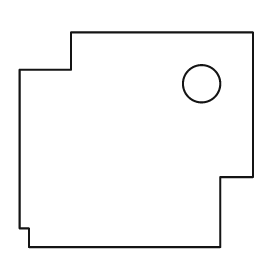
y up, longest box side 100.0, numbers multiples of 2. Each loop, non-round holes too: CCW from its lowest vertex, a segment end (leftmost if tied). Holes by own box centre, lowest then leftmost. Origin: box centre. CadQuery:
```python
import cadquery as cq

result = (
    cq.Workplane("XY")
    .moveTo(-46.0, -46.0)
    .lineTo(36.0, -46.0)
    .lineTo(36.0, -16.0)
    .lineTo(50.0, -16.0)
    .lineTo(50.0, 46.0)
    .lineTo(-28.0, 46.0)
    .lineTo(-28.0, 30.0)
    .lineTo(-50.0, 30.0)
    .lineTo(-50.0, -38.0)
    .lineTo(-46.0, -38.0)
    .close()
    .moveTo(28.0, 24.0)
    .circle(8.0)
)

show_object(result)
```